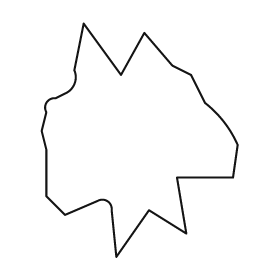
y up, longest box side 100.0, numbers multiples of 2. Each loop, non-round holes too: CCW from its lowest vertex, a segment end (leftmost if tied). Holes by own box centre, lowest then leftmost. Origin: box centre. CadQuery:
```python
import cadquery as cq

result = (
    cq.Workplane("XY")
    .moveTo(-10.0, -50.0)
    .lineTo(4.0, -30.0)
    .lineTo(20.0, -40.0)
    .lineTo(16.0, -16.0)
    .lineTo(40.0, -16.0)
    .lineTo(42.0, -2.0)
    .threePointArc((36.0, 8.0), (28.0, 16.0))
    .lineTo(22.0, 28.0)
    .lineTo(14.0, 32.0)
    .lineTo(2.0, 46.0)
    .lineTo(-8.0, 28.0)
    .lineTo(-24.0, 50.0)
    .lineTo(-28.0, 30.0)
    .threePointArc((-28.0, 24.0), (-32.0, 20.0))
    .lineTo(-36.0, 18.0)
    .threePointArc((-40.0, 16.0), (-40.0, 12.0))
    .lineTo(-42.0, 4.0)
    .lineTo(-40.0, -4.0)
    .lineTo(-40.0, -24.0)
    .lineTo(-32.0, -32.0)
    .lineTo(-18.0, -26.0)
    .threePointArc((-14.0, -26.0), (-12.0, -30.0))
    .close()
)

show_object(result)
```